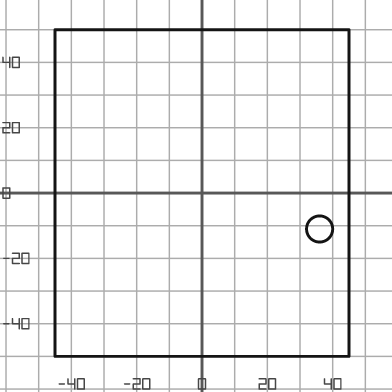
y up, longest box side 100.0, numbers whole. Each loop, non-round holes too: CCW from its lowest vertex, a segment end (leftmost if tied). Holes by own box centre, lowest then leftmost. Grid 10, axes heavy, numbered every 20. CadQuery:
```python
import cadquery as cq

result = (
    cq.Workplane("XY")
    .moveTo(-45.0, -50.0)
    .lineTo(45.0, -50.0)
    .lineTo(45.0, 50.0)
    .lineTo(-45.0, 50.0)
    .close()
    .moveTo(36.0, -11.0)
    .circle(4.0)
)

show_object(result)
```